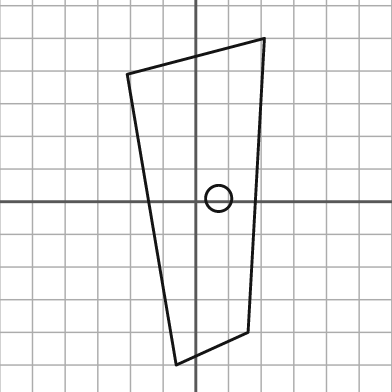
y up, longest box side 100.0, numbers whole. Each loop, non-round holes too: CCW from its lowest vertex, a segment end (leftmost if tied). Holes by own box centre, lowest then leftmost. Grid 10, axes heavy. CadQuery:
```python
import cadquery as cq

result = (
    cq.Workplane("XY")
    .moveTo(-6.0, -50.0)
    .lineTo(16.0, -40.0)
    .lineTo(21.0, 50.0)
    .lineTo(-21.0, 39.0)
    .close()
    .moveTo(7.0, 1.0)
    .circle(4.0)
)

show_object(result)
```